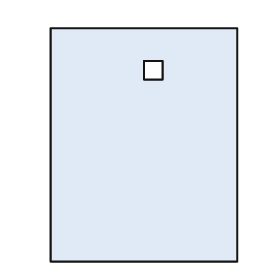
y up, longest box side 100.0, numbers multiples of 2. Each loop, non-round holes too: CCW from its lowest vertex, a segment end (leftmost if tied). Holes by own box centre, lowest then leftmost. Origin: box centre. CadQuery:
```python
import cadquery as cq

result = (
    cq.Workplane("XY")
    .moveTo(-40.0, -50.0)
    .lineTo(40.0, -50.0)
    .lineTo(40.0, 50.0)
    .lineTo(-40.0, 50.0)
    .close()
    .moveTo(0.0, 28.0)
    .lineTo(8.0, 28.0)
    .lineTo(8.0, 36.0)
    .lineTo(0.0, 36.0)
    .close()
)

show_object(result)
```